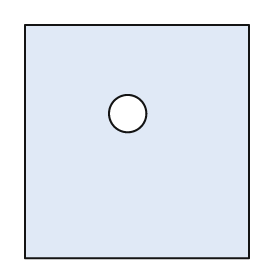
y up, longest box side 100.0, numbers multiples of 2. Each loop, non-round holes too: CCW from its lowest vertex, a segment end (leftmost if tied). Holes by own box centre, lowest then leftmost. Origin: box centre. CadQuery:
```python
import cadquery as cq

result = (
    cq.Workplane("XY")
    .moveTo(-48.0, -50.0)
    .lineTo(48.0, -50.0)
    .lineTo(48.0, 50.0)
    .lineTo(-48.0, 50.0)
    .close()
    .moveTo(-4.0, 12.0)
    .circle(8.0)
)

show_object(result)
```